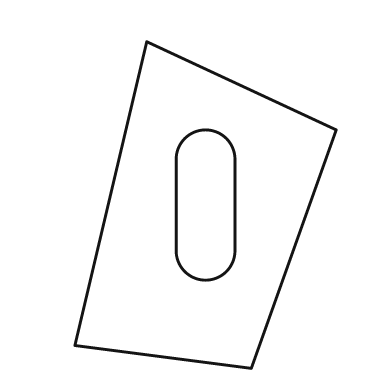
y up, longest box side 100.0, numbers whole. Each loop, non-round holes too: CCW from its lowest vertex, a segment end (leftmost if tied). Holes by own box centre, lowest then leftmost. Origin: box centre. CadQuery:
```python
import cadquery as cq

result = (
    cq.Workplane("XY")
    .moveTo(14.0, -50.0)
    .lineTo(40.0, 23.0)
    .lineTo(-18.0, 50.0)
    .lineTo(-40.0, -43.0)
    .close()
    .moveTo(-9.0, -14.0)
    .threePointArc((0.0, -23.0), (9.0, -14.0))
    .lineTo(9.0, 14.0)
    .threePointArc((0.0, 23.0), (-9.0, 14.0))
    .close()
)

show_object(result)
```